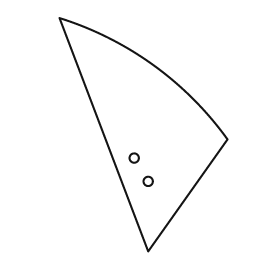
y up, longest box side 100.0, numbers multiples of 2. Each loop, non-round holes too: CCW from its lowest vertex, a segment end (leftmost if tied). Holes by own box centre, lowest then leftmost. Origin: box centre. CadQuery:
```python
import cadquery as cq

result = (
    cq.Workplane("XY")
    .moveTo(2.0, -50.0)
    .lineTo(36.0, -2.0)
    .threePointArc((4.0, 30.0), (-36.0, 50.0))
    .close()
    .moveTo(2.0, -20.0)
    .circle(2.0)
    .moveTo(-4.0, -10.0)
    .circle(2.0)
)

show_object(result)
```